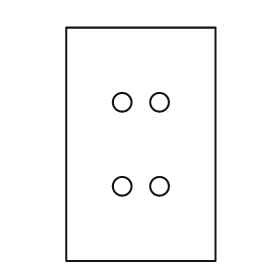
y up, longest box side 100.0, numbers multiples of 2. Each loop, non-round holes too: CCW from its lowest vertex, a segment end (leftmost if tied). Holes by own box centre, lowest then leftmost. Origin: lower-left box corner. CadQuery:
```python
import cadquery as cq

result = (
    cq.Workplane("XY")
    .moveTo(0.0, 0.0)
    .lineTo(64.0, 0.0)
    .lineTo(64.0, 100.0)
    .lineTo(0.0, 100.0)
    .close()
    .moveTo(24.0, 32.0)
    .circle(4.0)
    .moveTo(40.0, 32.0)
    .circle(4.0)
    .moveTo(24.0, 68.0)
    .circle(4.0)
    .moveTo(40.0, 68.0)
    .circle(4.0)
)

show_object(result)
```